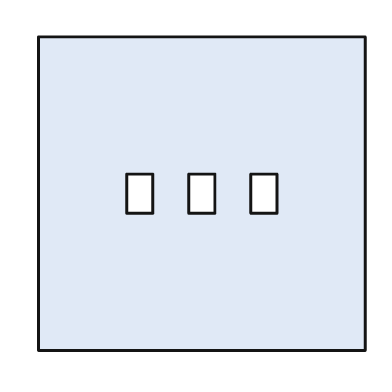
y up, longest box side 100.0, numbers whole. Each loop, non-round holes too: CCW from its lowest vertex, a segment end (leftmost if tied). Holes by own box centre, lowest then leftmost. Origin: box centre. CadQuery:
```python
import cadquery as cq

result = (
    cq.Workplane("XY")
    .moveTo(-50.0, -48.0)
    .lineTo(50.0, -48.0)
    .lineTo(50.0, 48.0)
    .lineTo(-50.0, 48.0)
    .close()
    .moveTo(-23.0, -6.0)
    .lineTo(-15.0, -6.0)
    .lineTo(-15.0, 6.0)
    .lineTo(-23.0, 6.0)
    .close()
    .moveTo(-4.0, -6.0)
    .lineTo(4.0, -6.0)
    .lineTo(4.0, 6.0)
    .lineTo(-4.0, 6.0)
    .close()
    .moveTo(15.0, -6.0)
    .lineTo(23.0, -6.0)
    .lineTo(23.0, 6.0)
    .lineTo(15.0, 6.0)
    .close()
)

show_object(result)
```